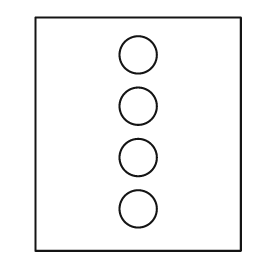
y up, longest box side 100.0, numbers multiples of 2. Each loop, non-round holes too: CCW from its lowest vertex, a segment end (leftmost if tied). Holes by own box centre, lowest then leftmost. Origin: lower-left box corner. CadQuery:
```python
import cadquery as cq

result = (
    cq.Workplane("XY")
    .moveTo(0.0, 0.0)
    .lineTo(88.0, 0.0)
    .lineTo(88.0, 100.0)
    .lineTo(0.0, 100.0)
    .close()
    .moveTo(44.0, 18.0)
    .circle(8.0)
    .moveTo(44.0, 40.0)
    .circle(8.0)
    .moveTo(44.0, 62.0)
    .circle(8.0)
    .moveTo(44.0, 84.0)
    .circle(8.0)
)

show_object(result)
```